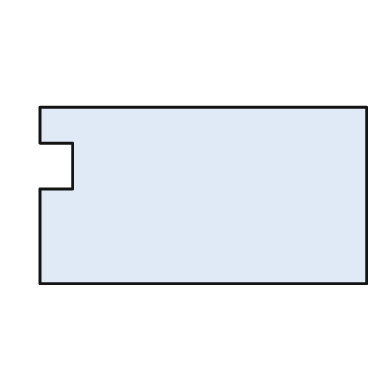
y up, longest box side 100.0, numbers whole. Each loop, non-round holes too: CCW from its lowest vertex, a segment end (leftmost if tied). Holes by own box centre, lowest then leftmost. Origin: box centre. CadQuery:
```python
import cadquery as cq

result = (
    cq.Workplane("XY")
    .moveTo(-50.0, -27.0)
    .lineTo(50.0, -27.0)
    .lineTo(50.0, 27.0)
    .lineTo(-50.0, 27.0)
    .lineTo(-50.0, 16.0)
    .lineTo(-40.0, 16.0)
    .lineTo(-40.0, 2.0)
    .lineTo(-50.0, 2.0)
    .close()
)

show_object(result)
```